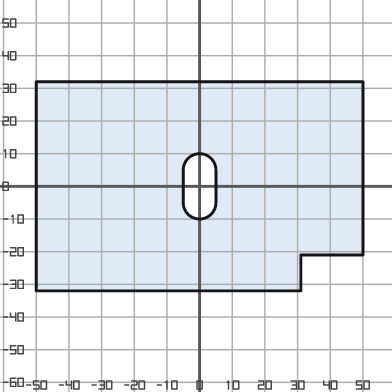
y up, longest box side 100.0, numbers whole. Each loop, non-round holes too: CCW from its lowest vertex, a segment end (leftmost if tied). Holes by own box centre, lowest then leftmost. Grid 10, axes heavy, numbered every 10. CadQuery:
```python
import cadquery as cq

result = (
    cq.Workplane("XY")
    .moveTo(-50.0, -32.0)
    .lineTo(31.0, -32.0)
    .lineTo(31.0, -21.0)
    .lineTo(50.0, -21.0)
    .lineTo(50.0, 32.0)
    .lineTo(-50.0, 32.0)
    .close()
    .moveTo(-5.0, -5.0)
    .threePointArc((0.0, -10.0), (5.0, -5.0))
    .lineTo(5.0, 5.0)
    .threePointArc((0.0, 10.0), (-5.0, 5.0))
    .close()
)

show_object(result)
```